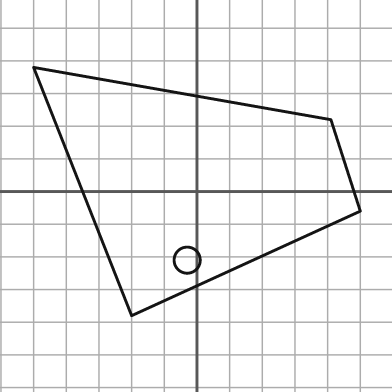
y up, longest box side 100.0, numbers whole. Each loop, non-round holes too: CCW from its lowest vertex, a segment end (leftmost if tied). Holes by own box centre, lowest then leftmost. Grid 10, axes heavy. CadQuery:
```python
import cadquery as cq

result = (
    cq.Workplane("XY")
    .moveTo(-20.0, -38.0)
    .lineTo(50.0, -6.0)
    .lineTo(41.0, 22.0)
    .lineTo(-50.0, 38.0)
    .close()
    .moveTo(-3.0, -21.0)
    .circle(4.0)
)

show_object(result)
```